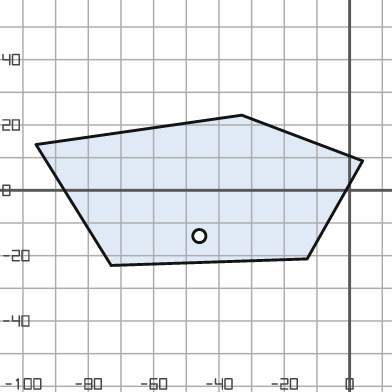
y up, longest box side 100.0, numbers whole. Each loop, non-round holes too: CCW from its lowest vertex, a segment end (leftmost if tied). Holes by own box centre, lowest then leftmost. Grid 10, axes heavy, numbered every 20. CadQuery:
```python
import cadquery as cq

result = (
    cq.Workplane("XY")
    .moveTo(-73.0, -23.0)
    .lineTo(-13.0, -21.0)
    .lineTo(4.0, 9.0)
    .lineTo(-33.0, 23.0)
    .lineTo(-96.0, 14.0)
    .close()
    .moveTo(-46.0, -14.0)
    .circle(2.0)
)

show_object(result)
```